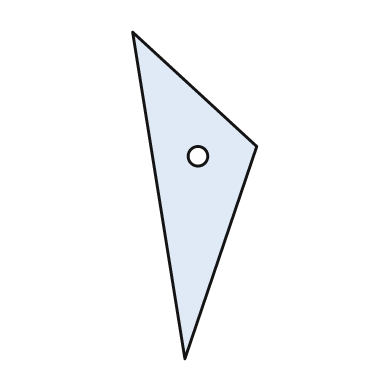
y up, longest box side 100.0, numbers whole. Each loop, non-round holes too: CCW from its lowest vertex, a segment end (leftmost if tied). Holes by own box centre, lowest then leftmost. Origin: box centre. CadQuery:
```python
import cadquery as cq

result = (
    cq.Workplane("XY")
    .moveTo(-3.0, -50.0)
    .lineTo(19.0, 15.0)
    .lineTo(-19.0, 50.0)
    .close()
    .moveTo(1.0, 12.0)
    .circle(3.0)
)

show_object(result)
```